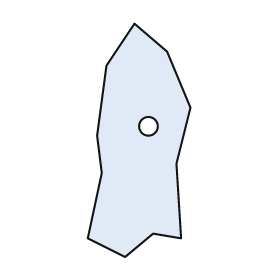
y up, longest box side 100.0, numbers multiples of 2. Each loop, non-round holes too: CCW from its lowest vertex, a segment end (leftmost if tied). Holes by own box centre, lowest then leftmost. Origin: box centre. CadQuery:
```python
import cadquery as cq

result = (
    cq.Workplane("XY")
    .moveTo(-6.0, -50.0)
    .lineTo(6.0, -40.0)
    .lineTo(18.0, -42.0)
    .lineTo(16.0, -10.0)
    .lineTo(22.0, 14.0)
    .lineTo(12.0, 38.0)
    .lineTo(-2.0, 50.0)
    .lineTo(-14.0, 32.0)
    .lineTo(-18.0, 2.0)
    .lineTo(-16.0, -14.0)
    .lineTo(-22.0, -42.0)
    .close()
    .moveTo(4.0, 6.0)
    .circle(4.0)
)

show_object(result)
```